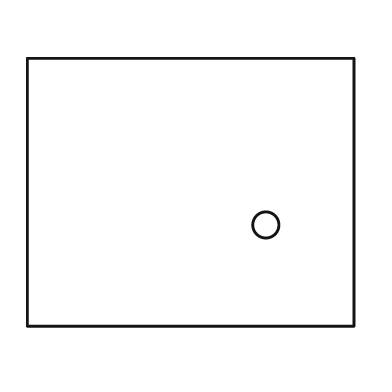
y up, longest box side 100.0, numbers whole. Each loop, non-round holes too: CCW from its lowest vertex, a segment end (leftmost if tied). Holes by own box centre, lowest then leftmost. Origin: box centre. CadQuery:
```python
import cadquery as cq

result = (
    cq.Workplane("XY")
    .moveTo(-50.0, -41.0)
    .lineTo(50.0, -41.0)
    .lineTo(50.0, 41.0)
    .lineTo(-50.0, 41.0)
    .close()
    .moveTo(23.0, -10.0)
    .circle(4.0)
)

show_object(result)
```